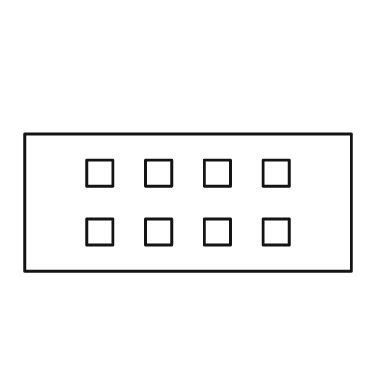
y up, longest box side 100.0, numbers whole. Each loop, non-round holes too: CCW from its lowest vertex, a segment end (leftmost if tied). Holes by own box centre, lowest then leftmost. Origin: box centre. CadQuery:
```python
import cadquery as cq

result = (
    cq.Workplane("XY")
    .moveTo(-50.0, -21.0)
    .lineTo(50.0, -21.0)
    .lineTo(50.0, 21.0)
    .lineTo(-50.0, 21.0)
    .close()
    .moveTo(-31.0, -13.0)
    .lineTo(-23.0, -13.0)
    .lineTo(-23.0, -5.0)
    .lineTo(-31.0, -5.0)
    .close()
    .moveTo(-13.0, -13.0)
    .lineTo(-5.0, -13.0)
    .lineTo(-5.0, -5.0)
    .lineTo(-13.0, -5.0)
    .close()
    .moveTo(5.0, -13.0)
    .lineTo(13.0, -13.0)
    .lineTo(13.0, -5.0)
    .lineTo(5.0, -5.0)
    .close()
    .moveTo(23.0, -13.0)
    .lineTo(31.0, -13.0)
    .lineTo(31.0, -5.0)
    .lineTo(23.0, -5.0)
    .close()
    .moveTo(-31.0, 5.0)
    .lineTo(-23.0, 5.0)
    .lineTo(-23.0, 13.0)
    .lineTo(-31.0, 13.0)
    .close()
    .moveTo(-13.0, 5.0)
    .lineTo(-5.0, 5.0)
    .lineTo(-5.0, 13.0)
    .lineTo(-13.0, 13.0)
    .close()
    .moveTo(5.0, 5.0)
    .lineTo(13.0, 5.0)
    .lineTo(13.0, 13.0)
    .lineTo(5.0, 13.0)
    .close()
    .moveTo(23.0, 5.0)
    .lineTo(31.0, 5.0)
    .lineTo(31.0, 13.0)
    .lineTo(23.0, 13.0)
    .close()
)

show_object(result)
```